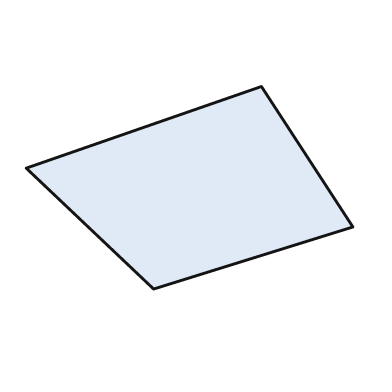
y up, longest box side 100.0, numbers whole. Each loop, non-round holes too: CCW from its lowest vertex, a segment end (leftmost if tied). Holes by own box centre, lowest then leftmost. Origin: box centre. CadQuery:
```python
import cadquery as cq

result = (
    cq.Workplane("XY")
    .moveTo(-11.0, -31.0)
    .lineTo(50.0, -12.0)
    .lineTo(22.0, 31.0)
    .lineTo(-50.0, 6.0)
    .close()
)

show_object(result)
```